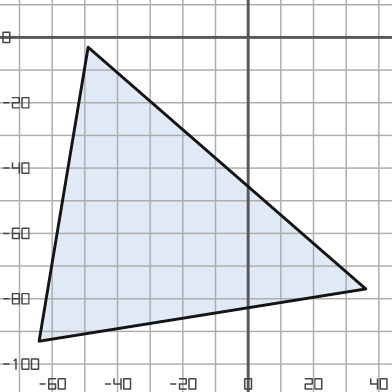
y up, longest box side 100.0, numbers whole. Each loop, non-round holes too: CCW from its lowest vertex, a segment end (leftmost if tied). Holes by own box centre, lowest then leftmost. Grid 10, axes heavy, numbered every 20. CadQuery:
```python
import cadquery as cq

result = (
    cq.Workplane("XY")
    .moveTo(-64.0, -93.0)
    .lineTo(36.0, -77.0)
    .lineTo(-49.0, -3.0)
    .close()
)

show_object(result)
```